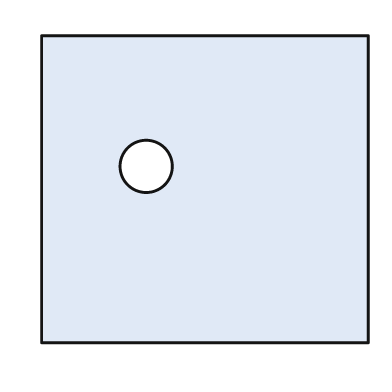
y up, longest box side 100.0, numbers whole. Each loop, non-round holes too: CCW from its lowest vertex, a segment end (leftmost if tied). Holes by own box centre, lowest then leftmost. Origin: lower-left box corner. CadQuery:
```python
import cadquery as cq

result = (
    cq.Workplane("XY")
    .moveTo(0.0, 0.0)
    .lineTo(100.0, 0.0)
    .lineTo(100.0, 94.0)
    .lineTo(0.0, 94.0)
    .close()
    .moveTo(32.0, 54.0)
    .circle(8.0)
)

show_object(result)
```